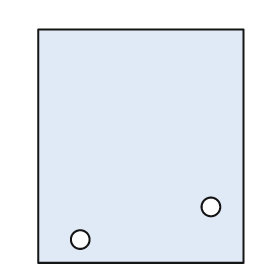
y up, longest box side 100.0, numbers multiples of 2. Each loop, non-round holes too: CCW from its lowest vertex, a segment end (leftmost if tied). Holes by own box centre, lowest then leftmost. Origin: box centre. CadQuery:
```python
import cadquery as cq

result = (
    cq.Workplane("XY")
    .moveTo(-44.0, -50.0)
    .lineTo(44.0, -50.0)
    .lineTo(44.0, 50.0)
    .lineTo(-44.0, 50.0)
    .close()
    .moveTo(-26.0, -40.0)
    .circle(4.0)
    .moveTo(30.0, -26.0)
    .circle(4.0)
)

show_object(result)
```